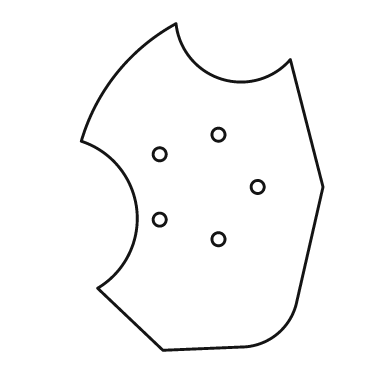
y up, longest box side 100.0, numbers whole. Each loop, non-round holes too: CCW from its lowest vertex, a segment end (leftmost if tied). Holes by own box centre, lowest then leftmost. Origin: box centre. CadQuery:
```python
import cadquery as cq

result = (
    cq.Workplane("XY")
    .moveTo(-12.0, -50.0)
    .lineTo(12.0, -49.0)
    .threePointArc((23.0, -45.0), (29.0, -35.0))
    .lineTo(37.0, 0.0)
    .lineTo(27.0, 39.0)
    .threePointArc((6.0, 33.0), (-8.0, 50.0))
    .threePointArc((-26.0, 35.0), (-37.0, 14.0))
    .threePointArc((-20.0, -7.0), (-32.0, -31.0))
    .close()
    .moveTo(5.0, -16.0)
    .circle(2.0)
    .moveTo(-13.0, -10.0)
    .circle(2.0)
    .moveTo(17.0, 0.0)
    .circle(2.0)
    .moveTo(-13.0, 10.0)
    .circle(2.0)
    .moveTo(5.0, 16.0)
    .circle(2.0)
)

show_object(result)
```